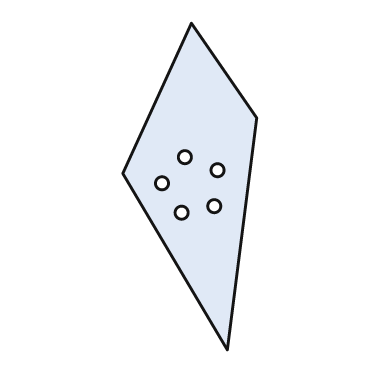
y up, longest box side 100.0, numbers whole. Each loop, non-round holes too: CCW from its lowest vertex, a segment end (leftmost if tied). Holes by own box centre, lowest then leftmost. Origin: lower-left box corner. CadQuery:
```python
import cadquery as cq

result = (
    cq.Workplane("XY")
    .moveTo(32.0, 0.0)
    .lineTo(41.0, 71.0)
    .lineTo(21.0, 100.0)
    .lineTo(0.0, 54.0)
    .close()
    .moveTo(18.0, 42.0)
    .circle(2.0)
    .moveTo(28.0, 44.0)
    .circle(2.0)
    .moveTo(12.0, 51.0)
    .circle(2.0)
    .moveTo(29.0, 55.0)
    .circle(2.0)
    .moveTo(19.0, 59.0)
    .circle(2.0)
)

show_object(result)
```